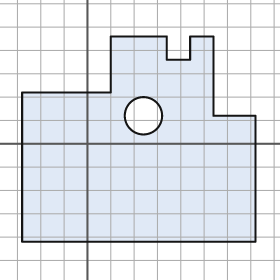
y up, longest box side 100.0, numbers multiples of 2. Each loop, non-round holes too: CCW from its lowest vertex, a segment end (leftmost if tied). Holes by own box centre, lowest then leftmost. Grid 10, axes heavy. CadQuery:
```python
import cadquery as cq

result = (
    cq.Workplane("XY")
    .moveTo(-28.0, -42.0)
    .lineTo(72.0, -42.0)
    .lineTo(72.0, 12.0)
    .lineTo(54.0, 12.0)
    .lineTo(54.0, 46.0)
    .lineTo(44.0, 46.0)
    .lineTo(44.0, 36.0)
    .lineTo(34.0, 36.0)
    .lineTo(34.0, 46.0)
    .lineTo(10.0, 46.0)
    .lineTo(10.0, 22.0)
    .lineTo(-28.0, 22.0)
    .close()
    .moveTo(24.0, 12.0)
    .circle(8.0)
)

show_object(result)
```